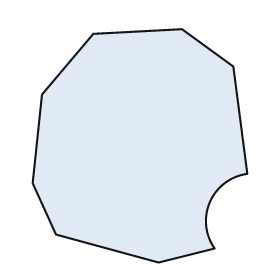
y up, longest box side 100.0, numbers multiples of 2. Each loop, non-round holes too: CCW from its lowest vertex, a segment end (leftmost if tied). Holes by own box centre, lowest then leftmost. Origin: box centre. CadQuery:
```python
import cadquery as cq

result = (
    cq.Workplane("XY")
    .moveTo(8.0, -50.0)
    .lineTo(32.0, -44.0)
    .threePointArc((30.0, -24.0), (46.0, -12.0))
    .lineTo(40.0, 34.0)
    .lineTo(18.0, 50.0)
    .lineTo(-20.0, 48.0)
    .lineTo(-42.0, 22.0)
    .lineTo(-46.0, -16.0)
    .lineTo(-36.0, -38.0)
    .close()
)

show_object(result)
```